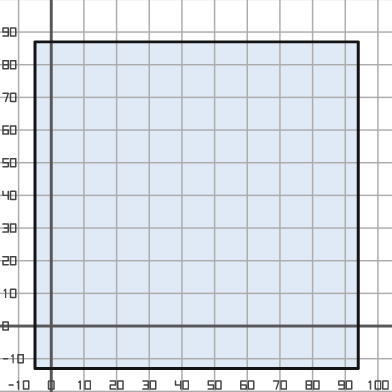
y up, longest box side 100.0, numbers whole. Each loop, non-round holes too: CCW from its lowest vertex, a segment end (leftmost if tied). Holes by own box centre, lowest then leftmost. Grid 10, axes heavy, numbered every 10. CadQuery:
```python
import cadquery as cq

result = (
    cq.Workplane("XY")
    .moveTo(-5.0, -13.0)
    .lineTo(94.0, -13.0)
    .lineTo(94.0, 87.0)
    .lineTo(-5.0, 87.0)
    .close()
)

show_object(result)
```